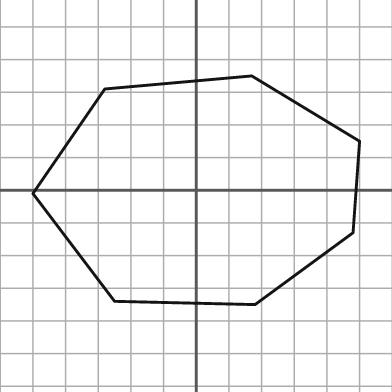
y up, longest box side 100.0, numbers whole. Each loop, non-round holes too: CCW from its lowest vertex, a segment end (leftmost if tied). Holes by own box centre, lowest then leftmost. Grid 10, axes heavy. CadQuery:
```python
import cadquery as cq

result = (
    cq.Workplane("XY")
    .moveTo(18.0, -35.0)
    .lineTo(48.0, -13.0)
    .lineTo(50.0, 15.0)
    .lineTo(17.0, 35.0)
    .lineTo(-28.0, 31.0)
    .lineTo(-50.0, -1.0)
    .lineTo(-25.0, -34.0)
    .close()
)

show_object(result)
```